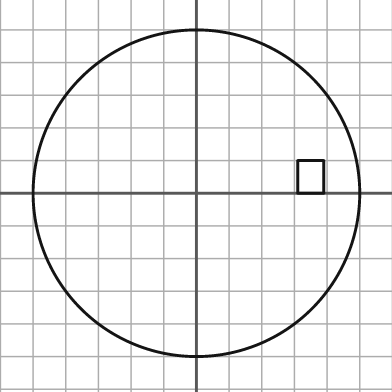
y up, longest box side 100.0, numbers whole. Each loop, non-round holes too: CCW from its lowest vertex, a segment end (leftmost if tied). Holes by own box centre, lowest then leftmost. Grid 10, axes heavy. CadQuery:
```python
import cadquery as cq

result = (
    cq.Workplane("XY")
    .moveTo(0.0, 0.0)
    .circle(50.0)
    .moveTo(31.0, 0.0)
    .lineTo(39.0, 0.0)
    .lineTo(39.0, 10.0)
    .lineTo(31.0, 10.0)
    .close()
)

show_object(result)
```